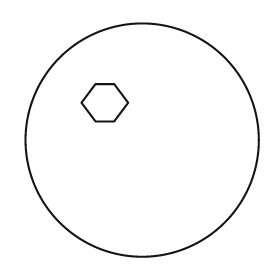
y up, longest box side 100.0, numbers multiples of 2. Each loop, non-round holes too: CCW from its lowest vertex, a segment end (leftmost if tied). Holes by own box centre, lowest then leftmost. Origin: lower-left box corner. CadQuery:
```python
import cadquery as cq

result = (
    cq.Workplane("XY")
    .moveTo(50.0, 50.0)
    .circle(50.0)
    .moveTo(30.0, 58.0)
    .lineTo(38.0, 58.0)
    .lineTo(44.0, 66.0)
    .lineTo(38.0, 74.0)
    .lineTo(30.0, 74.0)
    .lineTo(24.0, 66.0)
    .close()
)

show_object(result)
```